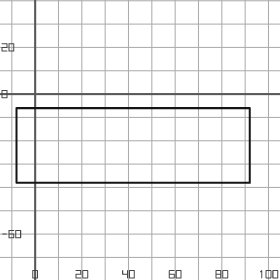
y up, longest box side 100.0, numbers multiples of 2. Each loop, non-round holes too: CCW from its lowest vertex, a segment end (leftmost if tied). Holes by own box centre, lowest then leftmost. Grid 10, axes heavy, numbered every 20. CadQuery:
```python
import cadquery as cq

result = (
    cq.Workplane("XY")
    .moveTo(-8.0, -38.0)
    .lineTo(92.0, -38.0)
    .lineTo(92.0, -6.0)
    .lineTo(-8.0, -6.0)
    .close()
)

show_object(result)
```